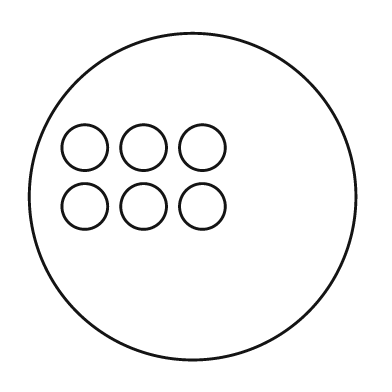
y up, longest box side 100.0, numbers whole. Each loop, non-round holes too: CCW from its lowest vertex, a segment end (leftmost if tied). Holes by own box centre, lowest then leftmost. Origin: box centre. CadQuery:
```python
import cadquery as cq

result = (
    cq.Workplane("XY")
    .moveTo(0.0, 0.0)
    .circle(50.0)
    .moveTo(-33.0, -3.0)
    .circle(7.0)
    .moveTo(-15.0, -3.0)
    .circle(7.0)
    .moveTo(3.0, -3.0)
    .circle(7.0)
    .moveTo(-33.0, 15.0)
    .circle(7.0)
    .moveTo(-15.0, 15.0)
    .circle(7.0)
    .moveTo(3.0, 15.0)
    .circle(7.0)
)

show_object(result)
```